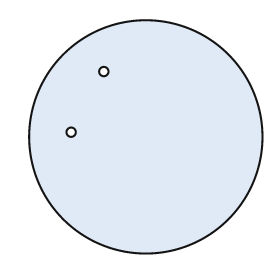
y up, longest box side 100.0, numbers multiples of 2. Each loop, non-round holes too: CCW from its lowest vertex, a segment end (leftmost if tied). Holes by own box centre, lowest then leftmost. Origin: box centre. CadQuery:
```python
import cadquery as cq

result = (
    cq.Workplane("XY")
    .moveTo(0.0, 0.0)
    .circle(50.0)
    .moveTo(-32.0, 2.0)
    .circle(2.0)
    .moveTo(-18.0, 28.0)
    .circle(2.0)
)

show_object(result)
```